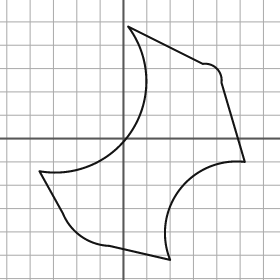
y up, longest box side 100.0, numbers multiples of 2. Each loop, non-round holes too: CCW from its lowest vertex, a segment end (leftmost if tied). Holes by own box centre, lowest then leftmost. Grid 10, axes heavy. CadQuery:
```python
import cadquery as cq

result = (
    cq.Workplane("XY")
    .moveTo(20.0, -52.0)
    .threePointArc((24.0, -22.0), (52.0, -10.0))
    .lineTo(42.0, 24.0)
    .threePointArc((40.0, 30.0), (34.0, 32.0))
    .lineTo(2.0, 48.0)
    .threePointArc((4.0, 4.0), (-36.0, -14.0))
    .lineTo(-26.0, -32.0)
    .threePointArc((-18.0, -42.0), (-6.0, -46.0))
    .close()
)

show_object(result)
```